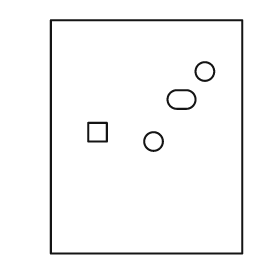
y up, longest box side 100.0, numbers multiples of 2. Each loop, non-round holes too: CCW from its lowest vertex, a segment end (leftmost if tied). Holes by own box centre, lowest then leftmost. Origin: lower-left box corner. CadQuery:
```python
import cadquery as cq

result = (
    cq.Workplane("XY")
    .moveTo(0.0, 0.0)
    .lineTo(82.0, 0.0)
    .lineTo(82.0, 100.0)
    .lineTo(0.0, 100.0)
    .close()
    .moveTo(44.0, 48.0)
    .circle(4.0)
    .moveTo(16.0, 48.0)
    .lineTo(24.0, 48.0)
    .lineTo(24.0, 56.0)
    .lineTo(16.0, 56.0)
    .close()
    .moveTo(54.0, 62.0)
    .lineTo(58.0, 62.0)
    .threePointArc((62.0, 66.0), (58.0, 70.0))
    .lineTo(54.0, 70.0)
    .threePointArc((50.0, 66.0), (54.0, 62.0))
    .close()
    .moveTo(66.0, 78.0)
    .circle(4.0)
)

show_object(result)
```